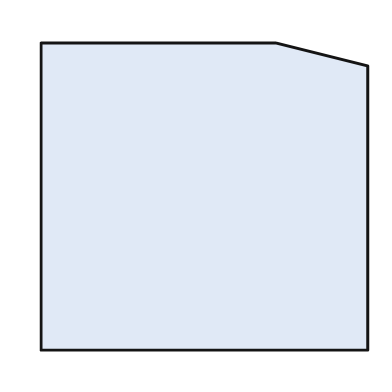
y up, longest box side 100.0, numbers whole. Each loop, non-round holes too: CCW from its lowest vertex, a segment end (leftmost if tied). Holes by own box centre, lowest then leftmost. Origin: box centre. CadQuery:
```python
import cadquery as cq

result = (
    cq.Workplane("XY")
    .moveTo(-50.0, -47.0)
    .lineTo(50.0, -47.0)
    .lineTo(50.0, 40.0)
    .lineTo(22.0, 47.0)
    .lineTo(-50.0, 47.0)
    .close()
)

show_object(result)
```